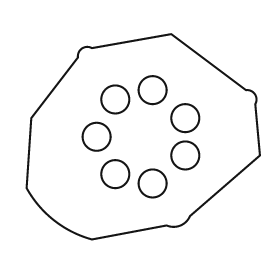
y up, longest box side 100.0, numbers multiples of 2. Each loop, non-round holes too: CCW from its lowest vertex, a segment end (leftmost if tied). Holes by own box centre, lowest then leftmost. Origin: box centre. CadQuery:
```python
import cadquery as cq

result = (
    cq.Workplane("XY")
    .moveTo(-22.0, -44.0)
    .lineTo(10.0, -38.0)
    .threePointArc((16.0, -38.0), (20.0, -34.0))
    .lineTo(50.0, -8.0)
    .lineTo(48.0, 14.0)
    .threePointArc((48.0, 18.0), (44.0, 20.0))
    .lineTo(12.0, 44.0)
    .lineTo(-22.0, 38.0)
    .threePointArc((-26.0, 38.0), (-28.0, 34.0))
    .lineTo(-48.0, 8.0)
    .lineTo(-50.0, -22.0)
    .threePointArc((-38.0, -36.0), (-22.0, -44.0))
    .close()
    .moveTo(4.0, -20.0)
    .circle(6.0)
    .moveTo(-12.0, -16.0)
    .circle(6.0)
    .moveTo(18.0, -8.0)
    .circle(6.0)
    .moveTo(-20.0, 0.0)
    .circle(6.0)
    .moveTo(18.0, 8.0)
    .circle(6.0)
    .moveTo(-12.0, 16.0)
    .circle(6.0)
    .moveTo(4.0, 20.0)
    .circle(6.0)
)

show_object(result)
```